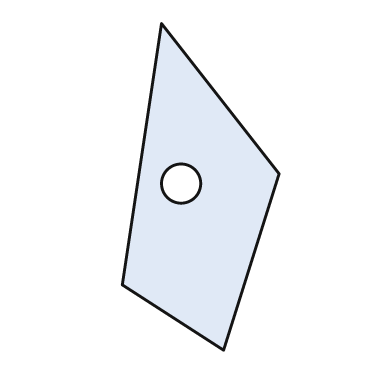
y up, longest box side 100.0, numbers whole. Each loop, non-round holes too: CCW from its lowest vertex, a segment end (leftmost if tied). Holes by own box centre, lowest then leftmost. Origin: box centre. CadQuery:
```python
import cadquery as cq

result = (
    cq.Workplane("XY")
    .moveTo(7.0, -50.0)
    .lineTo(24.0, 4.0)
    .lineTo(-12.0, 50.0)
    .lineTo(-24.0, -30.0)
    .close()
    .moveTo(-6.0, 1.0)
    .circle(6.0)
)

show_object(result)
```